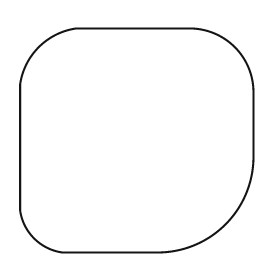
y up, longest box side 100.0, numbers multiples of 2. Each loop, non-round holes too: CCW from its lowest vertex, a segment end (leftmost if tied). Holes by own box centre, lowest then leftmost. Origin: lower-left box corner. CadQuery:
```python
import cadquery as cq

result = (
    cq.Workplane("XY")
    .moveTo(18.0, 0.0)
    .lineTo(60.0, 0.0)
    .threePointArc((88.0, 12.0), (100.0, 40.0))
    .lineTo(100.0, 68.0)
    .threePointArc((92.0, 88.0), (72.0, 96.0))
    .lineTo(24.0, 96.0)
    .threePointArc((8.0, 88.0), (0.0, 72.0))
    .lineTo(0.0, 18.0)
    .threePointArc((6.0, 6.0), (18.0, 0.0))
    .close()
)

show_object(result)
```